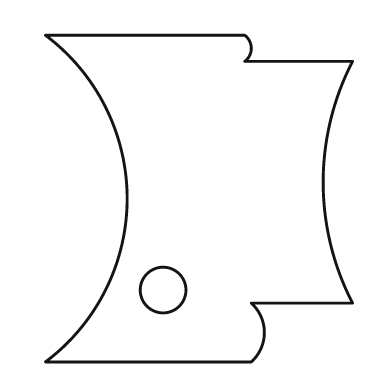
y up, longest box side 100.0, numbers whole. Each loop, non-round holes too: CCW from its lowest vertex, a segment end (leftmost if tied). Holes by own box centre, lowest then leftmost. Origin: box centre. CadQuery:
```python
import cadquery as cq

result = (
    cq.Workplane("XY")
    .moveTo(-47.0, -50.0)
    .lineTo(16.0, -50.0)
    .threePointArc((20.0, -41.0), (16.0, -32.0))
    .lineTo(47.0, -32.0)
    .threePointArc((38.0, 5.0), (47.0, 42.0))
    .lineTo(14.0, 42.0)
    .threePointArc((16.0, 46.0), (14.0, 50.0))
    .lineTo(-47.0, 50.0)
    .threePointArc((-22.0, 0.0), (-47.0, -50.0))
    .close()
    .moveTo(-11.0, -28.0)
    .circle(7.0)
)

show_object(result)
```